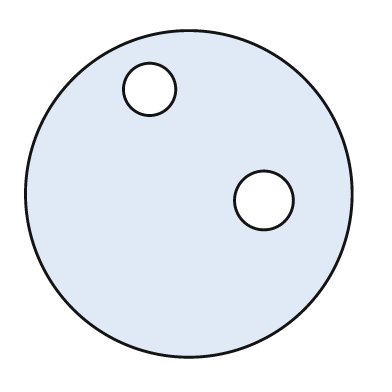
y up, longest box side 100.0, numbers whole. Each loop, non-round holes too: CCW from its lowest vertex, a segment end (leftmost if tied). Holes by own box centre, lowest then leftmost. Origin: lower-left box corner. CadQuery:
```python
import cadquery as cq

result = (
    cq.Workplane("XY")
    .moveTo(50.0, 50.0)
    .circle(50.0)
    .moveTo(73.0, 48.0)
    .circle(9.0)
    .moveTo(38.0, 82.0)
    .circle(8.0)
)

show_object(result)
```